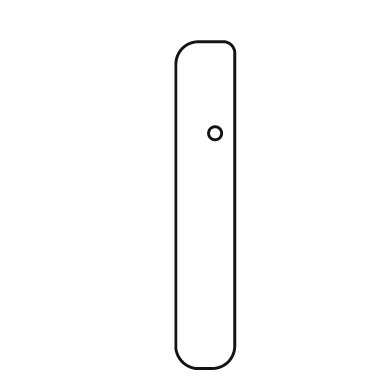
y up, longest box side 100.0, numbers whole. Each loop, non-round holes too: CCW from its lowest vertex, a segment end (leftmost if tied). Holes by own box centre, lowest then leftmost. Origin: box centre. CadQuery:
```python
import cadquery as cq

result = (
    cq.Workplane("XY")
    .moveTo(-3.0, -50.0)
    .lineTo(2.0, -50.0)
    .threePointArc((7.0, -48.0), (9.0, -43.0))
    .lineTo(9.0, 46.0)
    .threePointArc((8.0, 49.0), (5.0, 50.0))
    .lineTo(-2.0, 50.0)
    .threePointArc((-7.0, 48.0), (-9.0, 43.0))
    .lineTo(-9.0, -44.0)
    .threePointArc((-7.0, -48.0), (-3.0, -50.0))
    .close()
    .moveTo(3.0, 22.0)
    .circle(2.0)
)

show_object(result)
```